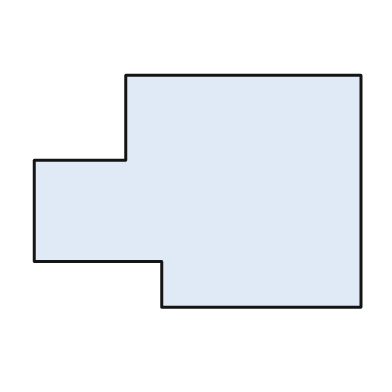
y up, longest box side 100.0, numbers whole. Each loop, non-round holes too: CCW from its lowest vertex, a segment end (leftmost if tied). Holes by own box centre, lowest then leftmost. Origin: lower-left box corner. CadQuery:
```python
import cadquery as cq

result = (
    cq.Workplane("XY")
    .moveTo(39.0, 0.0)
    .lineTo(100.0, 0.0)
    .lineTo(100.0, 71.0)
    .lineTo(28.0, 71.0)
    .lineTo(28.0, 45.0)
    .lineTo(0.0, 45.0)
    .lineTo(0.0, 14.0)
    .lineTo(39.0, 14.0)
    .close()
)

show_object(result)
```